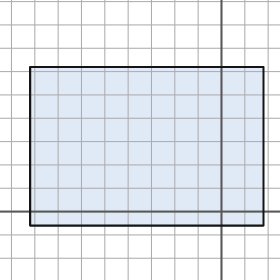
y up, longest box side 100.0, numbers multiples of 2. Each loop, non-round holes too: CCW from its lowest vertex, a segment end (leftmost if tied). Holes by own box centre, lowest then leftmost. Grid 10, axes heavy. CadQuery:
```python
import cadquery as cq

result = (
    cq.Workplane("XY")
    .moveTo(-82.0, -6.0)
    .lineTo(18.0, -6.0)
    .lineTo(18.0, 62.0)
    .lineTo(-82.0, 62.0)
    .close()
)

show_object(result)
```